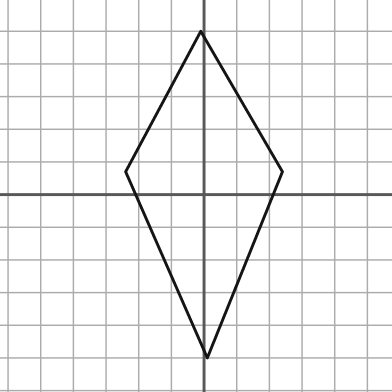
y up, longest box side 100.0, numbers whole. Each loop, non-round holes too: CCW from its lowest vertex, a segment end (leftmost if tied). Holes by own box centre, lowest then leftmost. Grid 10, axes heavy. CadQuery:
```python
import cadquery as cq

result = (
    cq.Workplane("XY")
    .moveTo(1.0, -50.0)
    .lineTo(24.0, 7.0)
    .lineTo(-1.0, 50.0)
    .lineTo(-24.0, 7.0)
    .close()
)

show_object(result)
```